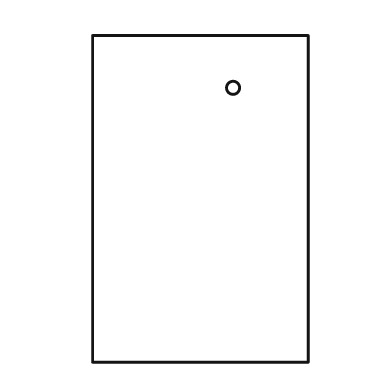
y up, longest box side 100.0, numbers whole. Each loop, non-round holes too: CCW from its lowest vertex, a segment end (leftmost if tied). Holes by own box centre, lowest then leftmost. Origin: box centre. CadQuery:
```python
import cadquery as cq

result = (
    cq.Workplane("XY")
    .moveTo(-33.0, -50.0)
    .lineTo(33.0, -50.0)
    .lineTo(33.0, 50.0)
    .lineTo(-33.0, 50.0)
    .close()
    .moveTo(10.0, 34.0)
    .circle(2.0)
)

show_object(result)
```